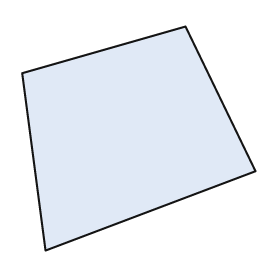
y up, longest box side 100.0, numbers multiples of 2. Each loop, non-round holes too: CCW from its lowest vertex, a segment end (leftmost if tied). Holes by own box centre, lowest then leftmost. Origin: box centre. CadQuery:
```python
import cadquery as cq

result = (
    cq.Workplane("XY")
    .moveTo(-40.0, -48.0)
    .lineTo(50.0, -14.0)
    .lineTo(20.0, 48.0)
    .lineTo(-50.0, 28.0)
    .close()
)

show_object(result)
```